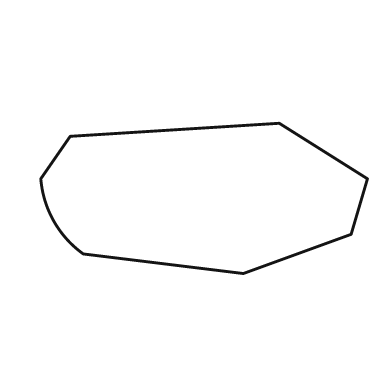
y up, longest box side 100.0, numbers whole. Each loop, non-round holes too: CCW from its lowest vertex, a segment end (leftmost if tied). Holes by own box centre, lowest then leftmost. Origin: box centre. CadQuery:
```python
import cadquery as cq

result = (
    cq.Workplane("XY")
    .moveTo(12.0, -23.0)
    .lineTo(45.0, -11.0)
    .lineTo(50.0, 6.0)
    .lineTo(23.0, 23.0)
    .lineTo(-41.0, 19.0)
    .lineTo(-50.0, 6.0)
    .threePointArc((-46.0, -7.0), (-37.0, -17.0))
    .close()
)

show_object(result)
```